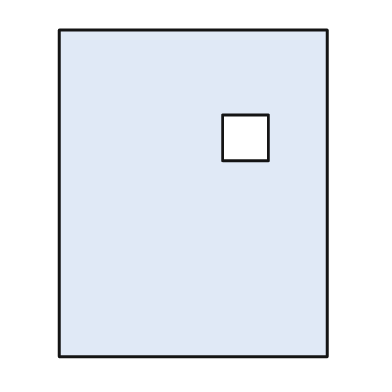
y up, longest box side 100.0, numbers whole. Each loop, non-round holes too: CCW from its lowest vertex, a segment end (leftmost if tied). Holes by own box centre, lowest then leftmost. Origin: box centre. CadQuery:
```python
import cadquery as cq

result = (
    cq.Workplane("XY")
    .moveTo(-41.0, -50.0)
    .lineTo(41.0, -50.0)
    .lineTo(41.0, 50.0)
    .lineTo(-41.0, 50.0)
    .close()
    .moveTo(9.0, 10.0)
    .lineTo(23.0, 10.0)
    .lineTo(23.0, 24.0)
    .lineTo(9.0, 24.0)
    .close()
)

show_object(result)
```